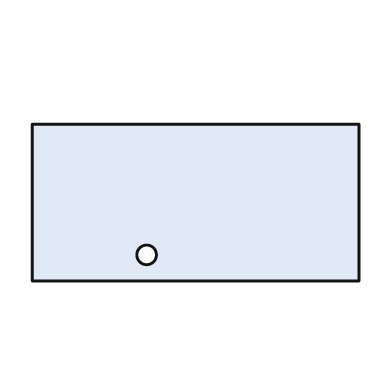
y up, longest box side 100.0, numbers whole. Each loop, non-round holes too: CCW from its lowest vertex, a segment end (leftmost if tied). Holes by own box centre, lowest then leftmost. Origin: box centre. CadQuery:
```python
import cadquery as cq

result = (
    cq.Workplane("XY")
    .moveTo(-50.0, -24.0)
    .lineTo(50.0, -24.0)
    .lineTo(50.0, 24.0)
    .lineTo(-50.0, 24.0)
    .close()
    .moveTo(-15.0, -16.0)
    .circle(3.0)
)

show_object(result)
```